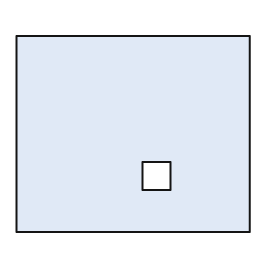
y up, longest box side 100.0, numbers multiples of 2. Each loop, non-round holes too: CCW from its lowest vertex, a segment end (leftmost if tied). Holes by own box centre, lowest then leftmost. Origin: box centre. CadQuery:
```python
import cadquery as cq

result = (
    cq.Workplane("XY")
    .moveTo(-50.0, -42.0)
    .lineTo(50.0, -42.0)
    .lineTo(50.0, 42.0)
    .lineTo(-50.0, 42.0)
    .close()
    .moveTo(4.0, -24.0)
    .lineTo(16.0, -24.0)
    .lineTo(16.0, -12.0)
    .lineTo(4.0, -12.0)
    .close()
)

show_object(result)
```